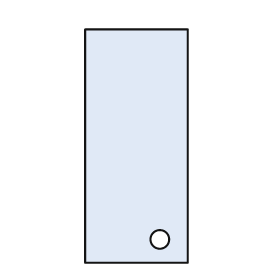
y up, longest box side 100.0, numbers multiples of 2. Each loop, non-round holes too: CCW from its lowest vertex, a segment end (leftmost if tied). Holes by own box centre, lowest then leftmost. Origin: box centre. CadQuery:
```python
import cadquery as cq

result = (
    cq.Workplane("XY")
    .moveTo(-22.0, -50.0)
    .lineTo(22.0, -50.0)
    .lineTo(22.0, 50.0)
    .lineTo(-22.0, 50.0)
    .close()
    .moveTo(10.0, -40.0)
    .circle(4.0)
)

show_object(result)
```